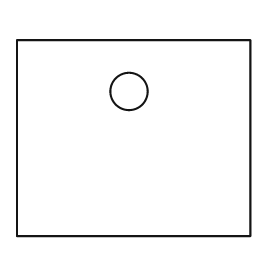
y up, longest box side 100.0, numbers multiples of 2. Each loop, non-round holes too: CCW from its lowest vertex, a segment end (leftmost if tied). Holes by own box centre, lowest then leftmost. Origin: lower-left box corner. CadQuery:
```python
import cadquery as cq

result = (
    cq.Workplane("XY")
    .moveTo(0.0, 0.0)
    .lineTo(100.0, 0.0)
    .lineTo(100.0, 84.0)
    .lineTo(0.0, 84.0)
    .close()
    .moveTo(48.0, 62.0)
    .circle(8.0)
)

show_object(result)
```